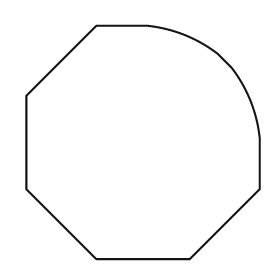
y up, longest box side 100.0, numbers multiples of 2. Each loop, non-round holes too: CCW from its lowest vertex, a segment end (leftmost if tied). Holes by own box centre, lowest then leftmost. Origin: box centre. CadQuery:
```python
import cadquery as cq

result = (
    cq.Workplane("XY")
    .moveTo(-20.0, -50.0)
    .lineTo(20.0, -50.0)
    .lineTo(50.0, -20.0)
    .lineTo(50.0, 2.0)
    .threePointArc((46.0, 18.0), (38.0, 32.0))
    .lineTo(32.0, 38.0)
    .threePointArc((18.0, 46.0), (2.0, 50.0))
    .lineTo(-20.0, 50.0)
    .lineTo(-50.0, 20.0)
    .lineTo(-50.0, -20.0)
    .close()
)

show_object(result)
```